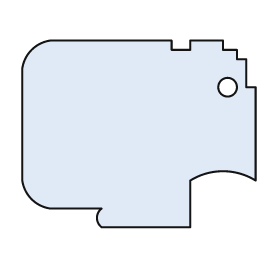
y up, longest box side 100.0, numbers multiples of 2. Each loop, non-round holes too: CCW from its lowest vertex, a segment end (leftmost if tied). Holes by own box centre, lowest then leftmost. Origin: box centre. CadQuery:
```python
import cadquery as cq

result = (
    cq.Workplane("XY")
    .moveTo(-16.0, -40.0)
    .lineTo(22.0, -40.0)
    .lineTo(22.0, -20.0)
    .threePointArc((36.0, -16.0), (50.0, -20.0))
    .lineTo(50.0, 20.0)
    .lineTo(46.0, 20.0)
    .lineTo(46.0, 32.0)
    .lineTo(42.0, 32.0)
    .lineTo(42.0, 36.0)
    .lineTo(36.0, 36.0)
    .lineTo(36.0, 40.0)
    .lineTo(22.0, 40.0)
    .lineTo(22.0, 36.0)
    .lineTo(14.0, 36.0)
    .lineTo(14.0, 40.0)
    .lineTo(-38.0, 40.0)
    .threePointArc((-46.0, 36.0), (-50.0, 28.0))
    .lineTo(-50.0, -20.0)
    .threePointArc((-46.0, -28.0), (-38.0, -32.0))
    .lineTo(-16.0, -32.0)
    .threePointArc((-18.0, -36.0), (-16.0, -40.0))
    .close()
    .moveTo(38.0, 20.0)
    .circle(4.0)
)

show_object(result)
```